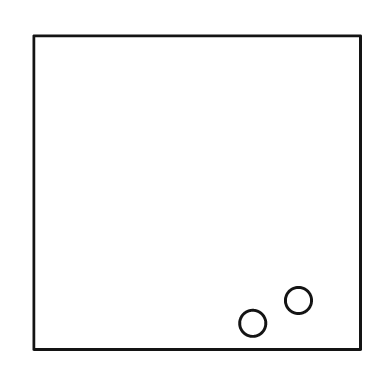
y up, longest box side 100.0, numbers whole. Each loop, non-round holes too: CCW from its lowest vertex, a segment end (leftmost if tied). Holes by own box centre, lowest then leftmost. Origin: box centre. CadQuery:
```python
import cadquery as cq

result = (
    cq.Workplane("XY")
    .moveTo(-50.0, -48.0)
    .lineTo(50.0, -48.0)
    .lineTo(50.0, 48.0)
    .lineTo(-50.0, 48.0)
    .close()
    .moveTo(17.0, -40.0)
    .circle(4.0)
    .moveTo(31.0, -33.0)
    .circle(4.0)
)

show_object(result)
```